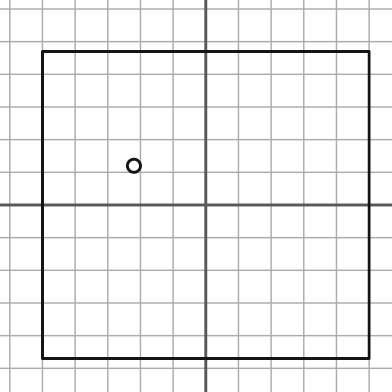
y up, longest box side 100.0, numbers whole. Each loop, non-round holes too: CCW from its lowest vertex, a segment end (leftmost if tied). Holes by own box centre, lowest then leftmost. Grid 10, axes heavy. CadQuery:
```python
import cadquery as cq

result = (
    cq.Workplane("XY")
    .moveTo(-50.0, -47.0)
    .lineTo(50.0, -47.0)
    .lineTo(50.0, 47.0)
    .lineTo(-50.0, 47.0)
    .close()
    .moveTo(-22.0, 12.0)
    .circle(2.0)
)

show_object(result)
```